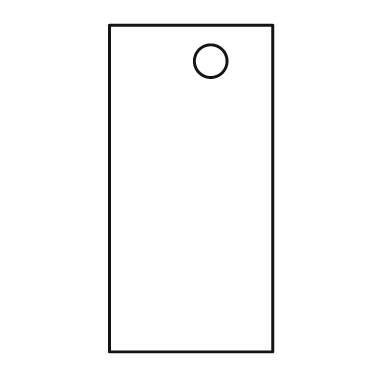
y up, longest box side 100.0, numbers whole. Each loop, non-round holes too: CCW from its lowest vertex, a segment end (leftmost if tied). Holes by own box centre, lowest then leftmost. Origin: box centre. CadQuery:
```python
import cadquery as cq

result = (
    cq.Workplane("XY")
    .moveTo(-25.0, -50.0)
    .lineTo(25.0, -50.0)
    .lineTo(25.0, 50.0)
    .lineTo(-25.0, 50.0)
    .close()
    .moveTo(6.0, 39.0)
    .circle(5.0)
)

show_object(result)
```